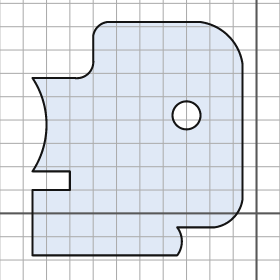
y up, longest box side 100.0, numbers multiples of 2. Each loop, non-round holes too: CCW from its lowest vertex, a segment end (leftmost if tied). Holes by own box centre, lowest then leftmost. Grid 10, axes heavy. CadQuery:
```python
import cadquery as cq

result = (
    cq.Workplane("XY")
    .moveTo(-96.0, -18.0)
    .lineTo(-34.0, -18.0)
    .threePointArc((-32.0, -12.0), (-34.0, -6.0))
    .lineTo(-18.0, -6.0)
    .threePointArc((-10.0, -2.0), (-6.0, 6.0))
    .lineTo(-6.0, 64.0)
    .threePointArc((-12.0, 76.0), (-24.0, 82.0))
    .lineTo(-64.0, 82.0)
    .threePointArc((-68.0, 80.0), (-70.0, 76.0))
    .lineTo(-70.0, 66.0)
    .threePointArc((-72.0, 60.0), (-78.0, 58.0))
    .lineTo(-96.0, 58.0)
    .threePointArc((-90.0, 38.0), (-96.0, 18.0))
    .lineTo(-80.0, 18.0)
    .lineTo(-80.0, 10.0)
    .lineTo(-96.0, 10.0)
    .close()
    .moveTo(-30.0, 42.0)
    .circle(6.0)
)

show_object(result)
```